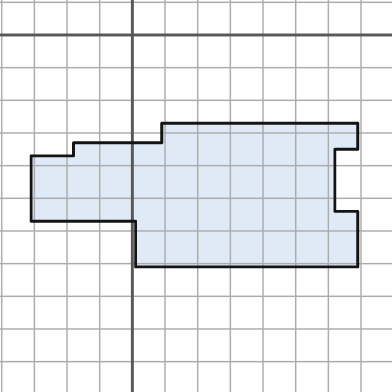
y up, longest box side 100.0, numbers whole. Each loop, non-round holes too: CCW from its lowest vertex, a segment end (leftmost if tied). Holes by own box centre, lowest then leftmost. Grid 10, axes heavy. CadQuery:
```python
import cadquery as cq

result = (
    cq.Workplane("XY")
    .moveTo(1.0, -71.0)
    .lineTo(69.0, -71.0)
    .lineTo(69.0, -54.0)
    .lineTo(62.0, -54.0)
    .lineTo(62.0, -35.0)
    .lineTo(69.0, -35.0)
    .lineTo(69.0, -27.0)
    .lineTo(9.0, -27.0)
    .lineTo(9.0, -33.0)
    .lineTo(-18.0, -33.0)
    .lineTo(-18.0, -37.0)
    .lineTo(-31.0, -37.0)
    .lineTo(-31.0, -57.0)
    .lineTo(1.0, -57.0)
    .close()
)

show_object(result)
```